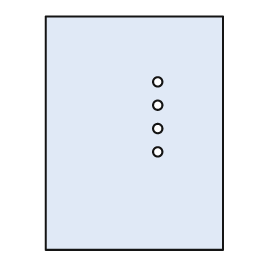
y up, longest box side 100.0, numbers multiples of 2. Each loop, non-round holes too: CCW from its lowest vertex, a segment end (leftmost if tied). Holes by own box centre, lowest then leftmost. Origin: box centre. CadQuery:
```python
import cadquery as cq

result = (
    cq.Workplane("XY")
    .moveTo(-38.0, -50.0)
    .lineTo(38.0, -50.0)
    .lineTo(38.0, 50.0)
    .lineTo(-38.0, 50.0)
    .close()
    .moveTo(10.0, -8.0)
    .circle(2.0)
    .moveTo(10.0, 2.0)
    .circle(2.0)
    .moveTo(10.0, 12.0)
    .circle(2.0)
    .moveTo(10.0, 22.0)
    .circle(2.0)
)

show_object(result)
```